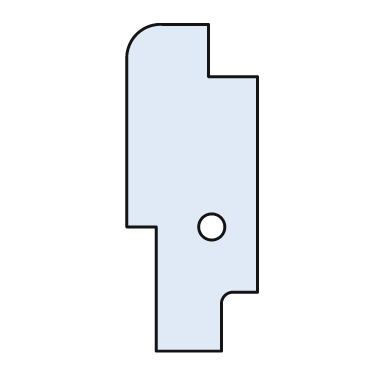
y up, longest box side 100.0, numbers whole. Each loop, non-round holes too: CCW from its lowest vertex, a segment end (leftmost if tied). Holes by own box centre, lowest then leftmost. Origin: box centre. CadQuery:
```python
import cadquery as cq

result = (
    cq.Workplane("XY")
    .moveTo(-11.0, -50.0)
    .lineTo(9.0, -50.0)
    .lineTo(9.0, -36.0)
    .threePointArc((10.0, -33.0), (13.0, -32.0))
    .lineTo(20.0, -32.0)
    .lineTo(20.0, 34.0)
    .lineTo(5.0, 34.0)
    .lineTo(5.0, 50.0)
    .lineTo(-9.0, 50.0)
    .threePointArc((-17.0, 47.0), (-20.0, 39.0))
    .lineTo(-20.0, -12.0)
    .lineTo(-11.0, -12.0)
    .close()
    .moveTo(6.0, -12.0)
    .circle(4.0)
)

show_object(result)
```